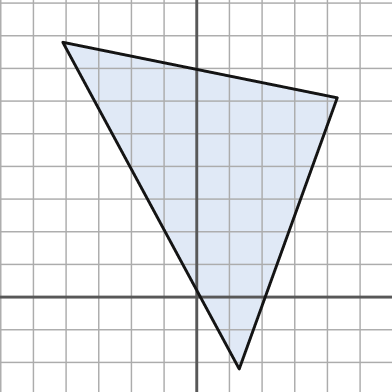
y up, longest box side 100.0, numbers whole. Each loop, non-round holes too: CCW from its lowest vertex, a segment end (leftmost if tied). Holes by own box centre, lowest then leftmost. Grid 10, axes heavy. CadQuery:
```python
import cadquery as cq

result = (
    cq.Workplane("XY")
    .moveTo(13.0, -22.0)
    .lineTo(43.0, 61.0)
    .lineTo(-41.0, 78.0)
    .close()
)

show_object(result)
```